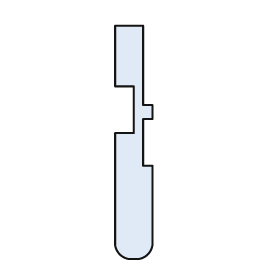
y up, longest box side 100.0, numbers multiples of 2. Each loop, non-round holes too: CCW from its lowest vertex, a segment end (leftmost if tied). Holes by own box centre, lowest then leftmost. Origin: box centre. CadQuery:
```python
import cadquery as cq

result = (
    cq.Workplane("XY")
    .moveTo(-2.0, -50.0)
    .lineTo(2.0, -50.0)
    .threePointArc((6.0, -48.0), (8.0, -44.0))
    .lineTo(8.0, -10.0)
    .lineTo(4.0, -10.0)
    .lineTo(4.0, 10.0)
    .lineTo(8.0, 10.0)
    .lineTo(8.0, 16.0)
    .lineTo(4.0, 16.0)
    .lineTo(4.0, 50.0)
    .lineTo(-8.0, 50.0)
    .lineTo(-8.0, 24.0)
    .lineTo(0.0, 24.0)
    .lineTo(0.0, 4.0)
    .lineTo(-8.0, 4.0)
    .lineTo(-8.0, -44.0)
    .threePointArc((-6.0, -48.0), (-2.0, -50.0))
    .close()
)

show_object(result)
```